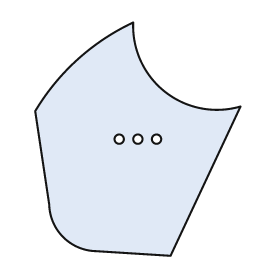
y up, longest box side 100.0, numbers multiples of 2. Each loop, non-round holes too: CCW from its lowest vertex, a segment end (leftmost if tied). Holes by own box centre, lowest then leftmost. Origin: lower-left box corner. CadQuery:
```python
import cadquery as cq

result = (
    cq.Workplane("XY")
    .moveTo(58.0, 0.0)
    .lineTo(88.0, 64.0)
    .threePointArc((56.0, 70.0), (42.0, 100.0))
    .threePointArc((18.0, 84.0), (0.0, 62.0))
    .lineTo(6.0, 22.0)
    .threePointArc((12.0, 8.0), (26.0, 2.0))
    .close()
    .moveTo(36.0, 50.0)
    .circle(2.0)
    .moveTo(44.0, 50.0)
    .circle(2.0)
    .moveTo(52.0, 50.0)
    .circle(2.0)
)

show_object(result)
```